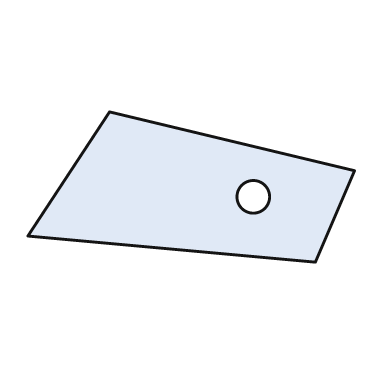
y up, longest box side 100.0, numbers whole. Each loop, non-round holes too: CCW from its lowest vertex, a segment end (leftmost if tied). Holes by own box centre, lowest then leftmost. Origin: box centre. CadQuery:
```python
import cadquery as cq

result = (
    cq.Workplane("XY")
    .moveTo(38.0, -23.0)
    .lineTo(50.0, 5.0)
    .lineTo(-25.0, 23.0)
    .lineTo(-50.0, -15.0)
    .close()
    .moveTo(19.0, -3.0)
    .circle(5.0)
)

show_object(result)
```